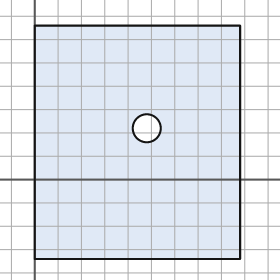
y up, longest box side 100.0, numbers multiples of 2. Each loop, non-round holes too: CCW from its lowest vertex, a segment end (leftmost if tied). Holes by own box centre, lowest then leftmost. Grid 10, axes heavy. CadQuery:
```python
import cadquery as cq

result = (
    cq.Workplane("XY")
    .moveTo(0.0, -34.0)
    .lineTo(88.0, -34.0)
    .lineTo(88.0, 66.0)
    .lineTo(0.0, 66.0)
    .close()
    .moveTo(48.0, 22.0)
    .circle(6.0)
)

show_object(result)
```